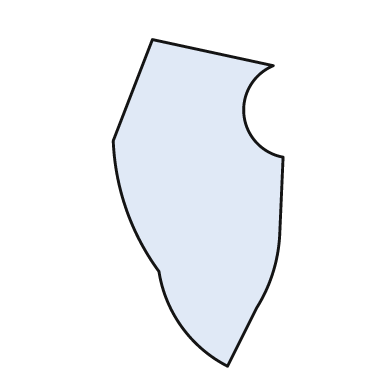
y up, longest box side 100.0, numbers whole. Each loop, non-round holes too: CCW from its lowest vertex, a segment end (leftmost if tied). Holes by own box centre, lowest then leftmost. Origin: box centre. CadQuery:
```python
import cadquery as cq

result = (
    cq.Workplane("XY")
    .moveTo(9.0, -50.0)
    .lineTo(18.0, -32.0)
    .threePointArc((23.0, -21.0), (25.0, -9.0))
    .lineTo(26.0, 14.0)
    .threePointArc((14.0, 27.0), (23.0, 42.0))
    .lineTo(-14.0, 50.0)
    .lineTo(-26.0, 19.0)
    .threePointArc((-22.0, -2.0), (-12.0, -21.0))
    .threePointArc((-5.0, -38.0), (9.0, -50.0))
    .close()
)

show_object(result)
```